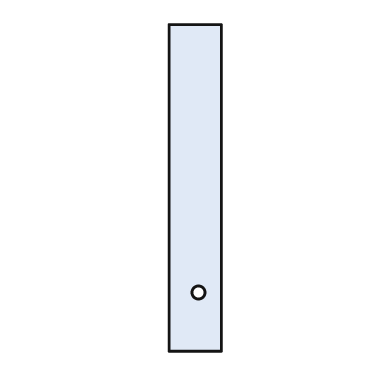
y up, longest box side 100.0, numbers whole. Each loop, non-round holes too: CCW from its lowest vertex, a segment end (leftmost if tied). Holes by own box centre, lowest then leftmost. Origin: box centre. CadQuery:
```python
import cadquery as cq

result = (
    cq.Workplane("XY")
    .moveTo(-8.0, -50.0)
    .lineTo(8.0, -50.0)
    .lineTo(8.0, 50.0)
    .lineTo(-8.0, 50.0)
    .close()
    .moveTo(1.0, -32.0)
    .circle(2.0)
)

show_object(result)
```